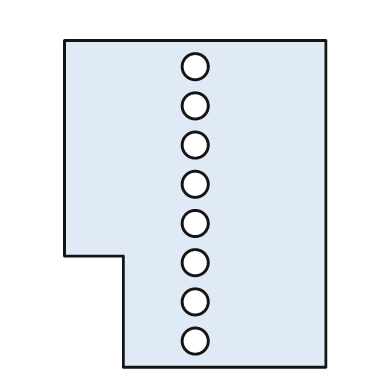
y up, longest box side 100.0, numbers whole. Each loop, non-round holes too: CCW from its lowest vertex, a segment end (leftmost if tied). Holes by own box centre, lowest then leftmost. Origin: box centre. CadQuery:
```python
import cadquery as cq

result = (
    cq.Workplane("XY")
    .moveTo(-22.0, -50.0)
    .lineTo(40.0, -50.0)
    .lineTo(40.0, 50.0)
    .lineTo(-40.0, 50.0)
    .lineTo(-40.0, -16.0)
    .lineTo(-22.0, -16.0)
    .close()
    .moveTo(0.0, -42.0)
    .circle(4.0)
    .moveTo(0.0, -30.0)
    .circle(4.0)
    .moveTo(0.0, -18.0)
    .circle(4.0)
    .moveTo(0.0, -6.0)
    .circle(4.0)
    .moveTo(0.0, 6.0)
    .circle(4.0)
    .moveTo(0.0, 18.0)
    .circle(4.0)
    .moveTo(0.0, 30.0)
    .circle(4.0)
    .moveTo(0.0, 42.0)
    .circle(4.0)
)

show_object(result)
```